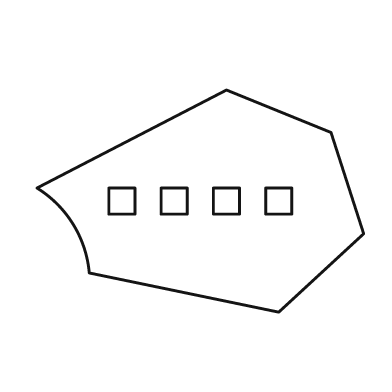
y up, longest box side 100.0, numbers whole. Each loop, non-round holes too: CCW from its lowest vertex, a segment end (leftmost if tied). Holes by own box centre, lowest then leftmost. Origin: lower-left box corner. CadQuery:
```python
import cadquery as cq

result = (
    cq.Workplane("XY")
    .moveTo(74.0, 0.0)
    .lineTo(100.0, 24.0)
    .lineTo(90.0, 55.0)
    .lineTo(58.0, 68.0)
    .lineTo(0.0, 38.0)
    .threePointArc((11.0, 27.0), (16.0, 12.0))
    .close()
    .moveTo(22.0, 30.0)
    .lineTo(30.0, 30.0)
    .lineTo(30.0, 38.0)
    .lineTo(22.0, 38.0)
    .close()
    .moveTo(38.0, 30.0)
    .lineTo(46.0, 30.0)
    .lineTo(46.0, 38.0)
    .lineTo(38.0, 38.0)
    .close()
    .moveTo(54.0, 30.0)
    .lineTo(62.0, 30.0)
    .lineTo(62.0, 38.0)
    .lineTo(54.0, 38.0)
    .close()
    .moveTo(70.0, 30.0)
    .lineTo(78.0, 30.0)
    .lineTo(78.0, 38.0)
    .lineTo(70.0, 38.0)
    .close()
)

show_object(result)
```